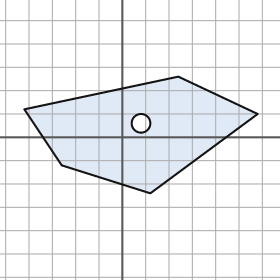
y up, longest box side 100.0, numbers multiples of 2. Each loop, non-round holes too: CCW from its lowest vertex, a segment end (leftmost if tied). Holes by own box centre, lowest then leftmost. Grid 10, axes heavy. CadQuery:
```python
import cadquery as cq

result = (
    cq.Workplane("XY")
    .moveTo(12.0, -24.0)
    .lineTo(58.0, 10.0)
    .lineTo(24.0, 26.0)
    .lineTo(-42.0, 12.0)
    .lineTo(-26.0, -12.0)
    .close()
    .moveTo(8.0, 6.0)
    .circle(4.0)
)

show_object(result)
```